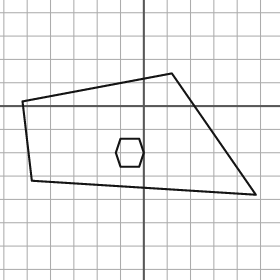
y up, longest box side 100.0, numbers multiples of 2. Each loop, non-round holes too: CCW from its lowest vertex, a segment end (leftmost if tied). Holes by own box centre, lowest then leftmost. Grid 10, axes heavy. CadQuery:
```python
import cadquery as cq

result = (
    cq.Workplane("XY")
    .moveTo(48.0, -38.0)
    .lineTo(12.0, 14.0)
    .lineTo(-52.0, 2.0)
    .lineTo(-48.0, -32.0)
    .close()
    .moveTo(-10.0, -26.0)
    .lineTo(-2.0, -26.0)
    .lineTo(0.0, -20.0)
    .lineTo(-2.0, -14.0)
    .lineTo(-10.0, -14.0)
    .lineTo(-12.0, -20.0)
    .close()
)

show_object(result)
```